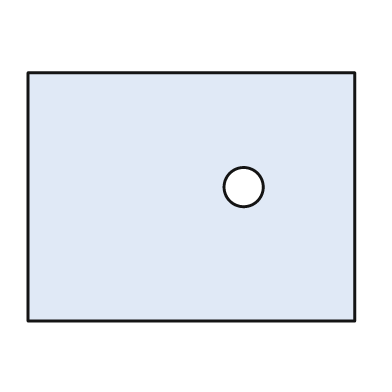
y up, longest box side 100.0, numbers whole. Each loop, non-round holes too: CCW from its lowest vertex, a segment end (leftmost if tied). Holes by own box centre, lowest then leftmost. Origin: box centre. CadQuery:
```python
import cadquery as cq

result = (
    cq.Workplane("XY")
    .moveTo(-50.0, -38.0)
    .lineTo(50.0, -38.0)
    .lineTo(50.0, 38.0)
    .lineTo(-50.0, 38.0)
    .close()
    .moveTo(16.0, 3.0)
    .circle(6.0)
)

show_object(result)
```